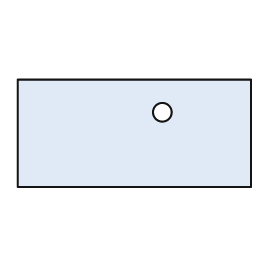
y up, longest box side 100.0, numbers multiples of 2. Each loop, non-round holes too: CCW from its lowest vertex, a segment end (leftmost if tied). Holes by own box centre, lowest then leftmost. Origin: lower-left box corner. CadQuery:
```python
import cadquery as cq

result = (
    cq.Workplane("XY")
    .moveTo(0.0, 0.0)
    .lineTo(100.0, 0.0)
    .lineTo(100.0, 46.0)
    .lineTo(0.0, 46.0)
    .close()
    .moveTo(62.0, 32.0)
    .circle(4.0)
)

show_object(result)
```